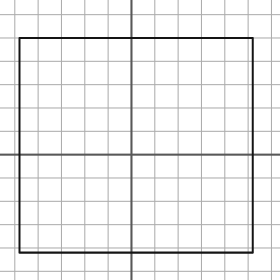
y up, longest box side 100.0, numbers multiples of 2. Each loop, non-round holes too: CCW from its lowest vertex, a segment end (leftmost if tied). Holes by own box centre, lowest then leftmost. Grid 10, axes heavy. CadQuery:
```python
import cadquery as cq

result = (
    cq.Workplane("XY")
    .moveTo(-48.0, -42.0)
    .lineTo(52.0, -42.0)
    .lineTo(52.0, 50.0)
    .lineTo(-48.0, 50.0)
    .close()
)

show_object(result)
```